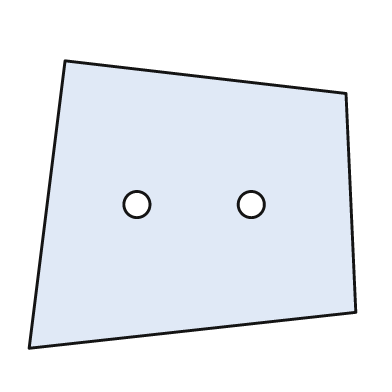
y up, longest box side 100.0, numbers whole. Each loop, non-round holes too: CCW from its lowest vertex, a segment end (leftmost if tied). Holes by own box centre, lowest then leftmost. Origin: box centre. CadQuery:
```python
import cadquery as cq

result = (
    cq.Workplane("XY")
    .moveTo(-50.0, -44.0)
    .lineTo(50.0, -33.0)
    .lineTo(47.0, 34.0)
    .lineTo(-39.0, 44.0)
    .close()
    .moveTo(-17.0, 0.0)
    .circle(4.0)
    .moveTo(18.0, 0.0)
    .circle(4.0)
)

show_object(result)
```